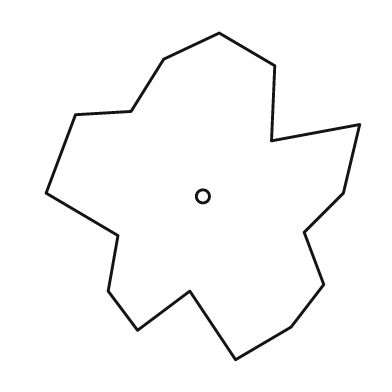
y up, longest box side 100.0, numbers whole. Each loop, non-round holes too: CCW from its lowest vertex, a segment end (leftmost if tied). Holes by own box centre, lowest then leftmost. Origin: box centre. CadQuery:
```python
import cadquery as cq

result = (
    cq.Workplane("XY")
    .moveTo(10.0, -50.0)
    .lineTo(27.0, -40.0)
    .lineTo(37.0, -27.0)
    .lineTo(31.0, -11.0)
    .lineTo(43.0, 1.0)
    .lineTo(48.0, 22.0)
    .lineTo(21.0, 17.0)
    .lineTo(22.0, 40.0)
    .lineTo(5.0, 50.0)
    .lineTo(-12.0, 42.0)
    .lineTo(-22.0, 26.0)
    .lineTo(-39.0, 25.0)
    .lineTo(-48.0, 1.0)
    .lineTo(-26.0, -12.0)
    .lineTo(-29.0, -29.0)
    .lineTo(-20.0, -41.0)
    .lineTo(-4.0, -29.0)
    .close()
    .moveTo(0.0, 0.0)
    .circle(2.0)
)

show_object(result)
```